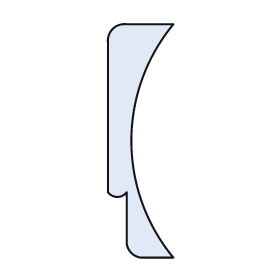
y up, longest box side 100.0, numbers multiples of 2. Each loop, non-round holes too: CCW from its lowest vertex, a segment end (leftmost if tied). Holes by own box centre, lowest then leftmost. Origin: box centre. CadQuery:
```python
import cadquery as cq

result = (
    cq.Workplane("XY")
    .moveTo(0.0, -50.0)
    .lineTo(14.0, -50.0)
    .threePointArc((-4.0, 0.0), (14.0, 50.0))
    .lineTo(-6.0, 50.0)
    .threePointArc((-12.0, 48.0), (-14.0, 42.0))
    .lineTo(-14.0, -22.0)
    .threePointArc((-10.0, -24.0), (-6.0, -22.0))
    .lineTo(-6.0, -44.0)
    .threePointArc((-4.0, -48.0), (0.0, -50.0))
    .close()
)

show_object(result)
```